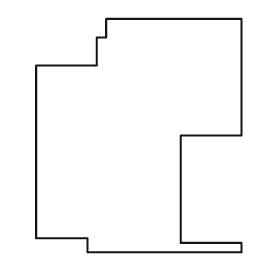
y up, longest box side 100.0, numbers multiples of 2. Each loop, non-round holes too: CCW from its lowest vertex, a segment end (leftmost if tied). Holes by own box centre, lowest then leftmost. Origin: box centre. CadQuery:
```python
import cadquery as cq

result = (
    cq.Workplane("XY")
    .moveTo(-22.0, -50.0)
    .lineTo(44.0, -50.0)
    .lineTo(44.0, -46.0)
    .lineTo(18.0, -46.0)
    .lineTo(18.0, 0.0)
    .lineTo(44.0, 0.0)
    .lineTo(44.0, 50.0)
    .lineTo(-14.0, 50.0)
    .lineTo(-14.0, 42.0)
    .lineTo(-18.0, 42.0)
    .lineTo(-18.0, 30.0)
    .lineTo(-44.0, 30.0)
    .lineTo(-44.0, -44.0)
    .lineTo(-22.0, -44.0)
    .close()
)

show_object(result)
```